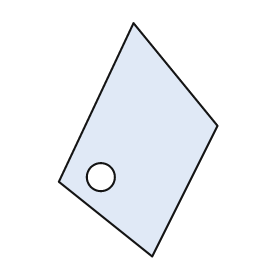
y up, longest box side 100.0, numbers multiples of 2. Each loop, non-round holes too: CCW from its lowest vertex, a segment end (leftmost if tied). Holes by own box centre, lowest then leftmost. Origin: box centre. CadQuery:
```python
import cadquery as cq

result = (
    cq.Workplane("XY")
    .moveTo(6.0, -50.0)
    .lineTo(34.0, 6.0)
    .lineTo(-2.0, 50.0)
    .lineTo(-34.0, -18.0)
    .close()
    .moveTo(-16.0, -16.0)
    .circle(6.0)
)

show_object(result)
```